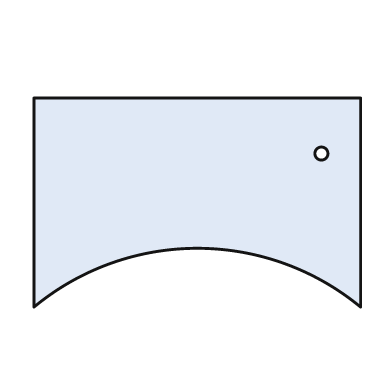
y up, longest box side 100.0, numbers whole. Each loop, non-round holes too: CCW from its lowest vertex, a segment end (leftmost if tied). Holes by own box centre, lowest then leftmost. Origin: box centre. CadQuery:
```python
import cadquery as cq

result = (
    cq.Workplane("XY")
    .moveTo(-50.0, -32.0)
    .threePointArc((0.0, -14.0), (50.0, -32.0))
    .lineTo(50.0, 32.0)
    .lineTo(-50.0, 32.0)
    .close()
    .moveTo(38.0, 15.0)
    .circle(2.0)
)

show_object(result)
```